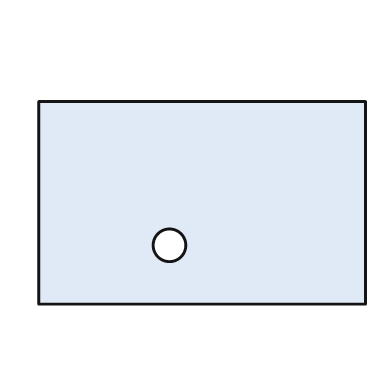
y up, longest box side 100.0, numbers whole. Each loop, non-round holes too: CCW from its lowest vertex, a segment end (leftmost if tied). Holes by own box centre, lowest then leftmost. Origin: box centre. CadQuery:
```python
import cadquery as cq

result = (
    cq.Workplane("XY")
    .moveTo(-50.0, -31.0)
    .lineTo(50.0, -31.0)
    .lineTo(50.0, 31.0)
    .lineTo(-50.0, 31.0)
    .close()
    .moveTo(-10.0, -13.0)
    .circle(5.0)
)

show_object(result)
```